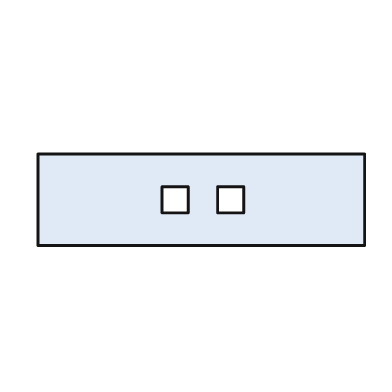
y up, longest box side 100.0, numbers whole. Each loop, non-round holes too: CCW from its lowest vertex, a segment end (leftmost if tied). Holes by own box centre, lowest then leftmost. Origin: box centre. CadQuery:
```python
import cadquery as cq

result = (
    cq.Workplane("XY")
    .moveTo(-50.0, -14.0)
    .lineTo(50.0, -14.0)
    .lineTo(50.0, 14.0)
    .lineTo(-50.0, 14.0)
    .close()
    .moveTo(-12.0, -4.0)
    .lineTo(-4.0, -4.0)
    .lineTo(-4.0, 4.0)
    .lineTo(-12.0, 4.0)
    .close()
    .moveTo(5.0, -4.0)
    .lineTo(13.0, -4.0)
    .lineTo(13.0, 4.0)
    .lineTo(5.0, 4.0)
    .close()
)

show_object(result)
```